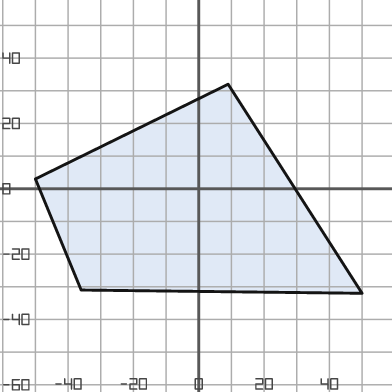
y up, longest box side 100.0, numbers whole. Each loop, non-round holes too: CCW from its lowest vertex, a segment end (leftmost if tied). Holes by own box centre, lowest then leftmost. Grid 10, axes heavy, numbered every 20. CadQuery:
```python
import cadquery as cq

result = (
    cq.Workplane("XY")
    .moveTo(50.0, -32.0)
    .lineTo(9.0, 32.0)
    .lineTo(-50.0, 3.0)
    .lineTo(-36.0, -31.0)
    .close()
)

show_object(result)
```